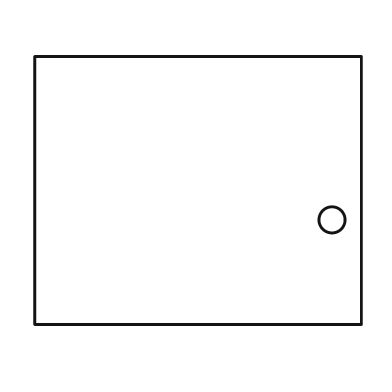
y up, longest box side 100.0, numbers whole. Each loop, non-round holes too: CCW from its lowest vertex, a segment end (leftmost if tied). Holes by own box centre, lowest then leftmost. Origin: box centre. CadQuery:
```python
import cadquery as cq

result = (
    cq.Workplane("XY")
    .moveTo(-50.0, -41.0)
    .lineTo(50.0, -41.0)
    .lineTo(50.0, 41.0)
    .lineTo(-50.0, 41.0)
    .close()
    .moveTo(41.0, -9.0)
    .circle(4.0)
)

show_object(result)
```